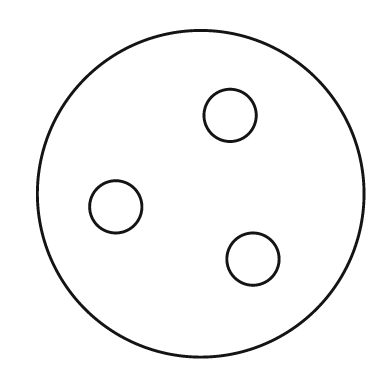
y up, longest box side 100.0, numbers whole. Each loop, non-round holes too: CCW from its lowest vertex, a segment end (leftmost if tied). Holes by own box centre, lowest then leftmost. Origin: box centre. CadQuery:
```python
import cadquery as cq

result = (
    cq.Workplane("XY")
    .moveTo(0.0, 0.0)
    .circle(50.0)
    .moveTo(16.0, -20.0)
    .circle(8.0)
    .moveTo(-26.0, -4.0)
    .circle(8.0)
    .moveTo(9.0, 24.0)
    .circle(8.0)
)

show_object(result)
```